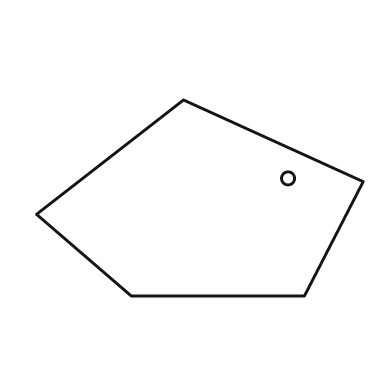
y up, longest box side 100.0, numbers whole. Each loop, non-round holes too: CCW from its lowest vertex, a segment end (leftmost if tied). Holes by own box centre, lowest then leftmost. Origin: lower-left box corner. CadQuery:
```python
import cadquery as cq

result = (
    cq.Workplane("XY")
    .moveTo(29.0, 0.0)
    .lineTo(82.0, 0.0)
    .lineTo(100.0, 35.0)
    .lineTo(45.0, 60.0)
    .lineTo(0.0, 25.0)
    .close()
    .moveTo(77.0, 36.0)
    .circle(2.0)
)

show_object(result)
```